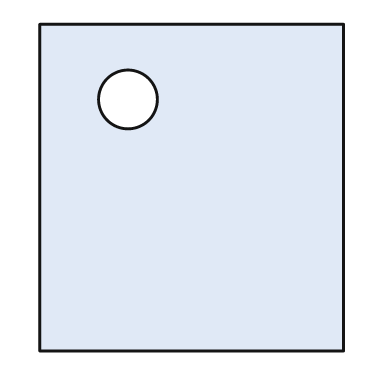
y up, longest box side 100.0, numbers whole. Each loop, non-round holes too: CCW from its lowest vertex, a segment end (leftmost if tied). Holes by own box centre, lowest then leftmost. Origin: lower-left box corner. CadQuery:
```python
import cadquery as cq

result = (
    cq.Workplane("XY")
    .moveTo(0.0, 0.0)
    .lineTo(93.0, 0.0)
    .lineTo(93.0, 100.0)
    .lineTo(0.0, 100.0)
    .close()
    .moveTo(27.0, 77.0)
    .circle(9.0)
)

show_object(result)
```